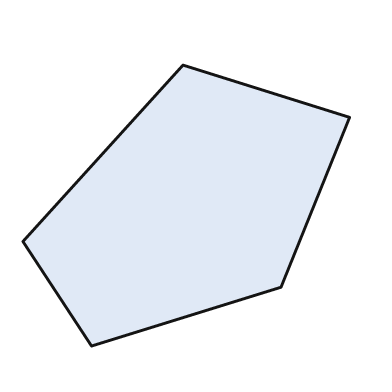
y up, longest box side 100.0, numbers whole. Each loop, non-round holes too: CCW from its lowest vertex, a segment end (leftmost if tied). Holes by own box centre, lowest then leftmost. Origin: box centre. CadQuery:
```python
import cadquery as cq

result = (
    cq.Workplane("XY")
    .moveTo(-29.0, -43.0)
    .lineTo(29.0, -25.0)
    .lineTo(50.0, 27.0)
    .lineTo(-1.0, 43.0)
    .lineTo(-50.0, -11.0)
    .close()
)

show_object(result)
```